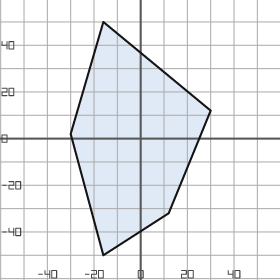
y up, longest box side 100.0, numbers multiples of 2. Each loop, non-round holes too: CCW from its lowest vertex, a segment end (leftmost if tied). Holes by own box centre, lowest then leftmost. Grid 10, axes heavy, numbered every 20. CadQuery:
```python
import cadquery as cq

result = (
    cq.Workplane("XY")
    .moveTo(-16.0, -50.0)
    .lineTo(12.0, -32.0)
    .lineTo(30.0, 12.0)
    .lineTo(-16.0, 50.0)
    .lineTo(-30.0, 2.0)
    .close()
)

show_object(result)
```